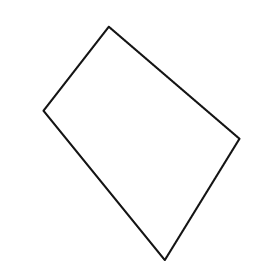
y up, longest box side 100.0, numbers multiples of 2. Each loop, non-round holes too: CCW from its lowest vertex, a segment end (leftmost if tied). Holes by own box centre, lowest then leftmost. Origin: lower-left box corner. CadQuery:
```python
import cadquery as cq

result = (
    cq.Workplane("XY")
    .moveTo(52.0, 0.0)
    .lineTo(84.0, 52.0)
    .lineTo(28.0, 100.0)
    .lineTo(0.0, 64.0)
    .close()
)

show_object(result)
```